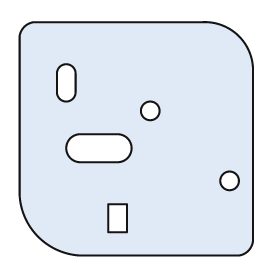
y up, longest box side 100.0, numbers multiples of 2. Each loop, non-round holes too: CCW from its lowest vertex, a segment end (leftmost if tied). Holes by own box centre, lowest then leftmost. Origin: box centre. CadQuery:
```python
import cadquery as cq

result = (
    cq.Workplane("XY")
    .moveTo(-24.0, -50.0)
    .lineTo(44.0, -50.0)
    .threePointArc((48.0, -48.0), (50.0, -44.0))
    .lineTo(50.0, 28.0)
    .threePointArc((44.0, 44.0), (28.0, 50.0))
    .lineTo(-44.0, 50.0)
    .threePointArc((-48.0, 48.0), (-50.0, 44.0))
    .lineTo(-50.0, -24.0)
    .threePointArc((-42.0, -42.0), (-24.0, -50.0))
    .close()
    .moveTo(-12.0, -40.0)
    .lineTo(-4.0, -40.0)
    .lineTo(-4.0, -28.0)
    .lineTo(-12.0, -28.0)
    .close()
    .moveTo(40.0, -18.0)
    .circle(4.0)
    .moveTo(-24.0, -10.0)
    .lineTo(-8.0, -10.0)
    .threePointArc((-2.0, -4.0), (-8.0, 2.0))
    .lineTo(-24.0, 2.0)
    .threePointArc((-30.0, -4.0), (-24.0, -10.0))
    .close()
    .moveTo(6.0, 12.0)
    .circle(4.0)
    .moveTo(-34.0, 20.0)
    .threePointArc((-30.0, 16.0), (-26.0, 20.0))
    .lineTo(-26.0, 28.0)
    .threePointArc((-30.0, 32.0), (-34.0, 28.0))
    .close()
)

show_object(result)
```